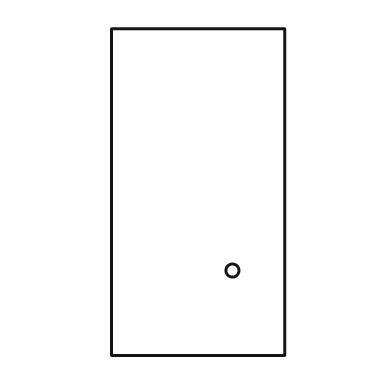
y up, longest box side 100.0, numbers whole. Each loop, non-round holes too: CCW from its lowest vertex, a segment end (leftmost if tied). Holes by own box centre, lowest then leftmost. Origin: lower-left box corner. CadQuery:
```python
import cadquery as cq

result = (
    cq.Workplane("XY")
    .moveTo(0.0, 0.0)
    .lineTo(53.0, 0.0)
    .lineTo(53.0, 100.0)
    .lineTo(0.0, 100.0)
    .close()
    .moveTo(37.0, 26.0)
    .circle(2.0)
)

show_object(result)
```